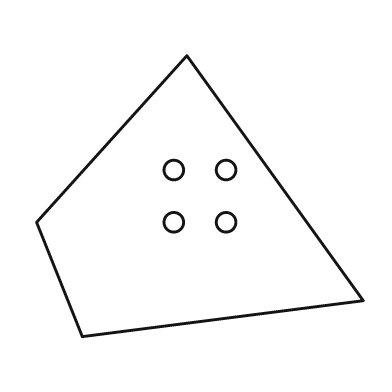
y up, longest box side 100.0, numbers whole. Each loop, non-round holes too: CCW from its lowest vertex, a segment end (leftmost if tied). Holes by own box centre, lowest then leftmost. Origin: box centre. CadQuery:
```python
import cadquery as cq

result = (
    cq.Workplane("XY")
    .moveTo(-36.0, -43.0)
    .lineTo(50.0, -32.0)
    .lineTo(-4.0, 43.0)
    .lineTo(-50.0, -8.0)
    .close()
    .moveTo(-8.0, -8.0)
    .circle(3.0)
    .moveTo(8.0, -8.0)
    .circle(3.0)
    .moveTo(-8.0, 8.0)
    .circle(3.0)
    .moveTo(8.0, 8.0)
    .circle(3.0)
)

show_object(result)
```